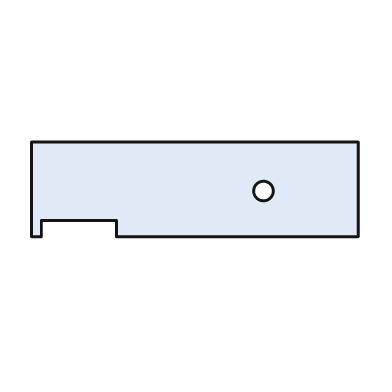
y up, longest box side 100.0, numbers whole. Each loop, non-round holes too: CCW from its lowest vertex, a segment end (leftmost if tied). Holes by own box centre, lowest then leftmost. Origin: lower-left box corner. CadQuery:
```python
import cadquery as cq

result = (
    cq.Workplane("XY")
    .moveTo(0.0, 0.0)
    .lineTo(3.0, 0.0)
    .lineTo(3.0, 5.0)
    .lineTo(26.0, 5.0)
    .lineTo(26.0, 0.0)
    .lineTo(100.0, 0.0)
    .lineTo(100.0, 29.0)
    .lineTo(0.0, 29.0)
    .close()
    .moveTo(71.0, 14.0)
    .circle(3.0)
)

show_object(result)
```